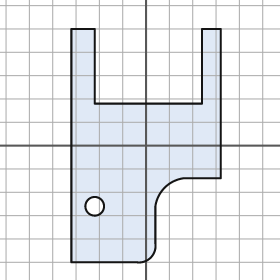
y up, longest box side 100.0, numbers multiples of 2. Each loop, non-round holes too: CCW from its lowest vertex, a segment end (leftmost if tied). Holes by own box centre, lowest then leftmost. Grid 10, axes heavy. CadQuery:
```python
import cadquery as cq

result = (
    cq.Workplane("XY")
    .moveTo(-32.0, -50.0)
    .lineTo(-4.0, -50.0)
    .threePointArc((2.0, -48.0), (4.0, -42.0))
    .lineTo(4.0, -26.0)
    .threePointArc((8.0, -18.0), (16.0, -14.0))
    .lineTo(32.0, -14.0)
    .lineTo(32.0, 50.0)
    .lineTo(24.0, 50.0)
    .lineTo(24.0, 18.0)
    .lineTo(-22.0, 18.0)
    .lineTo(-22.0, 50.0)
    .lineTo(-32.0, 50.0)
    .close()
    .moveTo(-22.0, -26.0)
    .circle(4.0)
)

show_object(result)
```